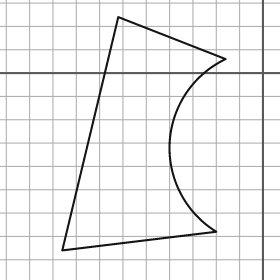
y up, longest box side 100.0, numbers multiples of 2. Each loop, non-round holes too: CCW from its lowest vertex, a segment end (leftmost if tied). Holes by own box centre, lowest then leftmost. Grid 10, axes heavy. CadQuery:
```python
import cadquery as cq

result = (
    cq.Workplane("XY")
    .moveTo(-86.0, -76.0)
    .lineTo(-20.0, -68.0)
    .threePointArc((-40.0, -30.0), (-16.0, 6.0))
    .lineTo(-62.0, 24.0)
    .close()
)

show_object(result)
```